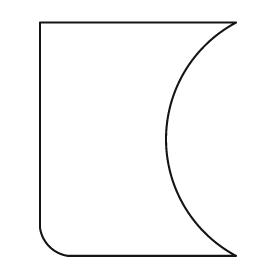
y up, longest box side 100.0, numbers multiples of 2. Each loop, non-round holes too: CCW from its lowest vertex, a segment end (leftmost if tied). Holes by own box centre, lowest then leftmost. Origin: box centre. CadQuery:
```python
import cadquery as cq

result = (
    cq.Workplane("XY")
    .moveTo(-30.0, -50.0)
    .lineTo(42.0, -50.0)
    .threePointArc((12.0, 0.0), (42.0, 50.0))
    .lineTo(-42.0, 50.0)
    .lineTo(-42.0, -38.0)
    .threePointArc((-38.0, -46.0), (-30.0, -50.0))
    .close()
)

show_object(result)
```